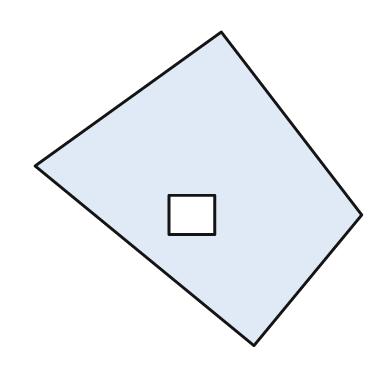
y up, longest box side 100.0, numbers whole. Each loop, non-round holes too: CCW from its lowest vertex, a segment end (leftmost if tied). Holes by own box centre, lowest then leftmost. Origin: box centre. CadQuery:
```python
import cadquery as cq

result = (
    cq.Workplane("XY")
    .moveTo(17.0, -48.0)
    .lineTo(50.0, -8.0)
    .lineTo(7.0, 48.0)
    .lineTo(-50.0, 7.0)
    .close()
    .moveTo(-9.0, -14.0)
    .lineTo(5.0, -14.0)
    .lineTo(5.0, -2.0)
    .lineTo(-9.0, -2.0)
    .close()
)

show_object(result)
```